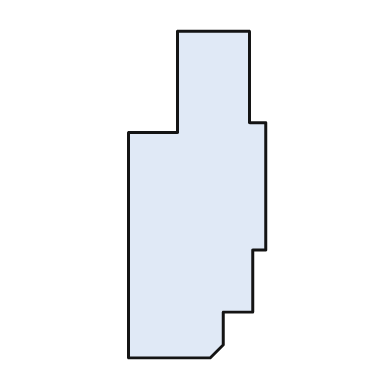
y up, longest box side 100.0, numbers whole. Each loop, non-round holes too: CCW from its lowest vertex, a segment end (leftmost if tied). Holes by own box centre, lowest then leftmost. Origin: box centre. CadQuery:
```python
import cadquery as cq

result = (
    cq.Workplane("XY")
    .moveTo(-21.0, -50.0)
    .lineTo(4.0, -50.0)
    .lineTo(8.0, -46.0)
    .lineTo(8.0, -36.0)
    .lineTo(17.0, -36.0)
    .lineTo(17.0, -17.0)
    .lineTo(21.0, -17.0)
    .lineTo(21.0, 22.0)
    .lineTo(16.0, 22.0)
    .lineTo(16.0, 50.0)
    .lineTo(-6.0, 50.0)
    .lineTo(-6.0, 19.0)
    .lineTo(-21.0, 19.0)
    .close()
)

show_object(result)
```